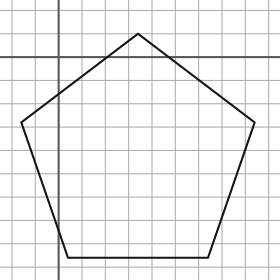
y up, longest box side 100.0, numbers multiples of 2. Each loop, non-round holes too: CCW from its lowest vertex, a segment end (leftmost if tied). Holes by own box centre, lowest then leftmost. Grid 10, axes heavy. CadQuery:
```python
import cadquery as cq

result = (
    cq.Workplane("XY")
    .moveTo(4.0, -86.0)
    .lineTo(64.0, -86.0)
    .lineTo(84.0, -28.0)
    .lineTo(34.0, 10.0)
    .lineTo(-16.0, -28.0)
    .close()
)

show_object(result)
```